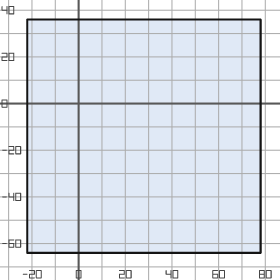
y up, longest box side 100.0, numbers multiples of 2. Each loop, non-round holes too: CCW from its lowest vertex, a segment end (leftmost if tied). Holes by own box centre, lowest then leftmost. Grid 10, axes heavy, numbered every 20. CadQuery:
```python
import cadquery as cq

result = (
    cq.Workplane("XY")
    .moveTo(-22.0, -64.0)
    .lineTo(78.0, -64.0)
    .lineTo(78.0, 36.0)
    .lineTo(-22.0, 36.0)
    .close()
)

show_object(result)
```